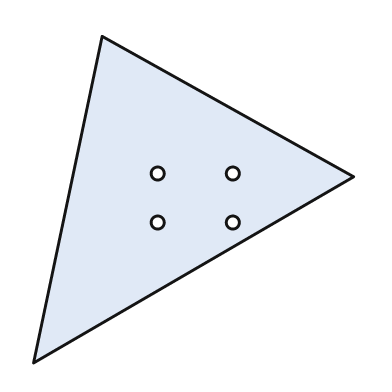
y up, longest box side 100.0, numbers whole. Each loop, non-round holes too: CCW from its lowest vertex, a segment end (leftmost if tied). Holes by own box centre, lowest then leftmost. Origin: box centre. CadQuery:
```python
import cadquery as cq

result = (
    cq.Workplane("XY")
    .moveTo(-49.0, -50.0)
    .lineTo(49.0, 7.0)
    .lineTo(-28.0, 50.0)
    .close()
    .moveTo(-11.0, -7.0)
    .circle(2.0)
    .moveTo(12.0, -7.0)
    .circle(2.0)
    .moveTo(-11.0, 8.0)
    .circle(2.0)
    .moveTo(12.0, 8.0)
    .circle(2.0)
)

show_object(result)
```